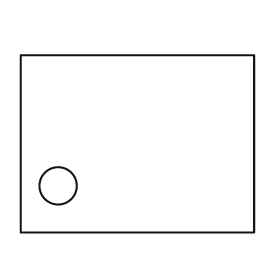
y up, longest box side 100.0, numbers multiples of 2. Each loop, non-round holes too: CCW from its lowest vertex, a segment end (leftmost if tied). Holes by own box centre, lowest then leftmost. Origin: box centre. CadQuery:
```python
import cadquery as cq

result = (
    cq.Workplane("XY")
    .moveTo(-50.0, -38.0)
    .lineTo(50.0, -38.0)
    .lineTo(50.0, 38.0)
    .lineTo(-50.0, 38.0)
    .close()
    .moveTo(-34.0, -18.0)
    .circle(8.0)
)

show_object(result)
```